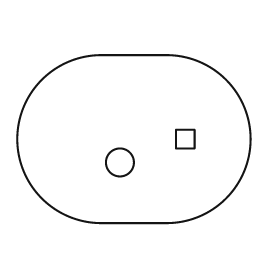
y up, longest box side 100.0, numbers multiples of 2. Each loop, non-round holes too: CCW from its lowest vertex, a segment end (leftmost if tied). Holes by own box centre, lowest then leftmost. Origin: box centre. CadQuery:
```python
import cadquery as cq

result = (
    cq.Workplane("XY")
    .moveTo(-14.0, -36.0)
    .lineTo(14.0, -36.0)
    .threePointArc((50.0, 0.0), (14.0, 36.0))
    .lineTo(-14.0, 36.0)
    .threePointArc((-50.0, 0.0), (-14.0, -36.0))
    .close()
    .moveTo(-6.0, -10.0)
    .circle(6.0)
    .moveTo(18.0, -4.0)
    .lineTo(26.0, -4.0)
    .lineTo(26.0, 4.0)
    .lineTo(18.0, 4.0)
    .close()
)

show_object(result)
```